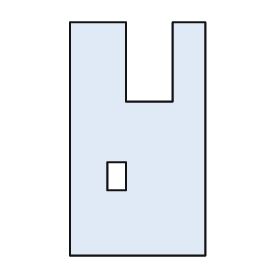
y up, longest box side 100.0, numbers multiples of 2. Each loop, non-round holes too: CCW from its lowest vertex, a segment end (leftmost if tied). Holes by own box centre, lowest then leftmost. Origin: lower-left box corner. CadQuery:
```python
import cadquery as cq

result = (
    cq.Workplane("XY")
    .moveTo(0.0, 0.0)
    .lineTo(58.0, 0.0)
    .lineTo(58.0, 100.0)
    .lineTo(44.0, 100.0)
    .lineTo(44.0, 66.0)
    .lineTo(24.0, 66.0)
    .lineTo(24.0, 100.0)
    .lineTo(0.0, 100.0)
    .close()
    .moveTo(16.0, 28.0)
    .lineTo(24.0, 28.0)
    .lineTo(24.0, 40.0)
    .lineTo(16.0, 40.0)
    .close()
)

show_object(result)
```